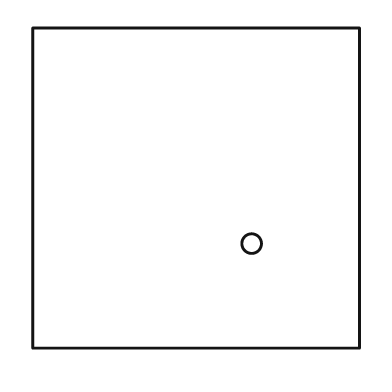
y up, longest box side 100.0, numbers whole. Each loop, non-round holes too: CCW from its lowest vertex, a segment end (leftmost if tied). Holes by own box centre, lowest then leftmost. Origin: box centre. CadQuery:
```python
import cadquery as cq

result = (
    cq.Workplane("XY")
    .moveTo(-50.0, -49.0)
    .lineTo(50.0, -49.0)
    .lineTo(50.0, 49.0)
    .lineTo(-50.0, 49.0)
    .close()
    .moveTo(17.0, -17.0)
    .circle(3.0)
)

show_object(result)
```